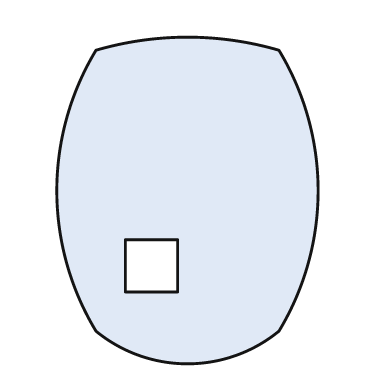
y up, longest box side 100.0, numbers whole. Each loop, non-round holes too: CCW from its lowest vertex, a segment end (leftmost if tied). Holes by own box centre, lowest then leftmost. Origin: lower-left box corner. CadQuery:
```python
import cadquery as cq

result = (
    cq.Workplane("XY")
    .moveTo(12.0, 10.0)
    .threePointArc((40.0, 0.0), (68.0, 10.0))
    .threePointArc((80.0, 53.0), (68.0, 96.0))
    .threePointArc((40.0, 100.0), (12.0, 96.0))
    .threePointArc((0.0, 53.0), (12.0, 10.0))
    .close()
    .moveTo(21.0, 22.0)
    .lineTo(37.0, 22.0)
    .lineTo(37.0, 38.0)
    .lineTo(21.0, 38.0)
    .close()
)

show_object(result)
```